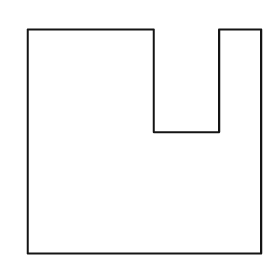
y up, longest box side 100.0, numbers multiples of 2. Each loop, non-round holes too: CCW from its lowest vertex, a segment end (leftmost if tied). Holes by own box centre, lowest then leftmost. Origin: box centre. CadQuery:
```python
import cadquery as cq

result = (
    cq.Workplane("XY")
    .moveTo(-50.0, -48.0)
    .lineTo(50.0, -48.0)
    .lineTo(50.0, 48.0)
    .lineTo(32.0, 48.0)
    .lineTo(32.0, 4.0)
    .lineTo(4.0, 4.0)
    .lineTo(4.0, 48.0)
    .lineTo(-50.0, 48.0)
    .close()
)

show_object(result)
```